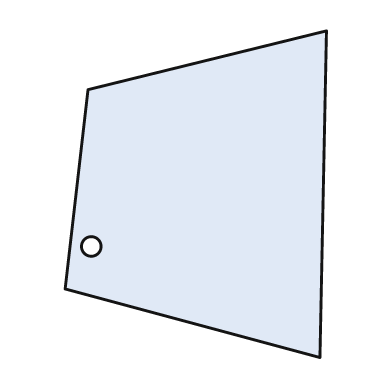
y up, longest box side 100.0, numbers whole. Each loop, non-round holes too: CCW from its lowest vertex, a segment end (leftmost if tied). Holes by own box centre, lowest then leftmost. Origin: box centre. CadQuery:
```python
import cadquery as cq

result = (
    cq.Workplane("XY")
    .moveTo(38.0, -50.0)
    .lineTo(40.0, 50.0)
    .lineTo(-33.0, 32.0)
    .lineTo(-40.0, -29.0)
    .close()
    .moveTo(-32.0, -16.0)
    .circle(3.0)
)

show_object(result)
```